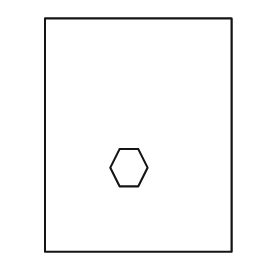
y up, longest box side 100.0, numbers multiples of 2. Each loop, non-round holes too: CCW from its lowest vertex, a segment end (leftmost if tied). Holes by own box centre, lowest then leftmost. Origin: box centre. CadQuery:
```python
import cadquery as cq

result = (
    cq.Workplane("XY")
    .moveTo(-40.0, -50.0)
    .lineTo(40.0, -50.0)
    .lineTo(40.0, 50.0)
    .lineTo(-40.0, 50.0)
    .close()
    .moveTo(-8.0, -22.0)
    .lineTo(0.0, -22.0)
    .lineTo(4.0, -14.0)
    .lineTo(0.0, -6.0)
    .lineTo(-8.0, -6.0)
    .lineTo(-12.0, -14.0)
    .close()
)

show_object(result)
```